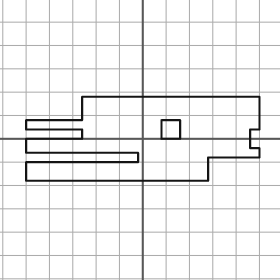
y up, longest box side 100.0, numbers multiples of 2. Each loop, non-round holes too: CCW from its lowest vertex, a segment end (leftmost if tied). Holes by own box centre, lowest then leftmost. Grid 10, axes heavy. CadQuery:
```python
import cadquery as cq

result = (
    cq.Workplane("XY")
    .moveTo(-50.0, -18.0)
    .lineTo(28.0, -18.0)
    .lineTo(28.0, -8.0)
    .lineTo(50.0, -8.0)
    .lineTo(50.0, -4.0)
    .lineTo(46.0, -4.0)
    .lineTo(46.0, 4.0)
    .lineTo(50.0, 4.0)
    .lineTo(50.0, 18.0)
    .lineTo(-26.0, 18.0)
    .lineTo(-26.0, 8.0)
    .lineTo(-50.0, 8.0)
    .lineTo(-50.0, 4.0)
    .lineTo(-26.0, 4.0)
    .lineTo(-26.0, 0.0)
    .lineTo(-50.0, 0.0)
    .lineTo(-50.0, -6.0)
    .lineTo(-2.0, -6.0)
    .lineTo(-2.0, -10.0)
    .lineTo(-50.0, -10.0)
    .close()
    .moveTo(8.0, 0.0)
    .lineTo(16.0, 0.0)
    .lineTo(16.0, 8.0)
    .lineTo(8.0, 8.0)
    .close()
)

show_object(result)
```